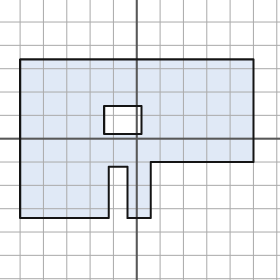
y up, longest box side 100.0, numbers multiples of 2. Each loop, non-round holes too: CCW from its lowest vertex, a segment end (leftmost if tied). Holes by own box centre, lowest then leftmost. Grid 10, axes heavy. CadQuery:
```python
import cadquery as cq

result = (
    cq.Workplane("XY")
    .moveTo(-50.0, -34.0)
    .lineTo(-12.0, -34.0)
    .lineTo(-12.0, -12.0)
    .lineTo(-4.0, -12.0)
    .lineTo(-4.0, -34.0)
    .lineTo(6.0, -34.0)
    .lineTo(6.0, -10.0)
    .lineTo(50.0, -10.0)
    .lineTo(50.0, 34.0)
    .lineTo(-50.0, 34.0)
    .close()
    .moveTo(-14.0, 2.0)
    .lineTo(2.0, 2.0)
    .lineTo(2.0, 14.0)
    .lineTo(-14.0, 14.0)
    .close()
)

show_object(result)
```